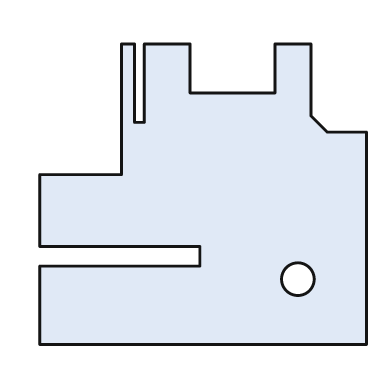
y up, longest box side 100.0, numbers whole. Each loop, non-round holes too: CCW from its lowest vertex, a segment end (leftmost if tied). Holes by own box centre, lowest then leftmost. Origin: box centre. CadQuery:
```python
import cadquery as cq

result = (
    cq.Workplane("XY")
    .moveTo(-50.0, -46.0)
    .lineTo(50.0, -46.0)
    .lineTo(50.0, 19.0)
    .lineTo(38.0, 19.0)
    .lineTo(33.0, 24.0)
    .lineTo(33.0, 46.0)
    .lineTo(22.0, 46.0)
    .lineTo(22.0, 31.0)
    .lineTo(-4.0, 31.0)
    .lineTo(-4.0, 46.0)
    .lineTo(-18.0, 46.0)
    .lineTo(-18.0, 22.0)
    .lineTo(-21.0, 22.0)
    .lineTo(-21.0, 46.0)
    .lineTo(-25.0, 46.0)
    .lineTo(-25.0, 6.0)
    .lineTo(-50.0, 6.0)
    .lineTo(-50.0, -16.0)
    .lineTo(-1.0, -16.0)
    .lineTo(-1.0, -22.0)
    .lineTo(-50.0, -22.0)
    .close()
    .moveTo(29.0, -26.0)
    .circle(5.0)
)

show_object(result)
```